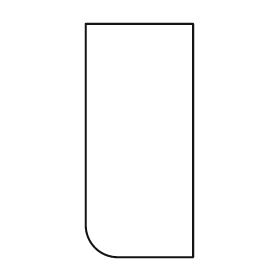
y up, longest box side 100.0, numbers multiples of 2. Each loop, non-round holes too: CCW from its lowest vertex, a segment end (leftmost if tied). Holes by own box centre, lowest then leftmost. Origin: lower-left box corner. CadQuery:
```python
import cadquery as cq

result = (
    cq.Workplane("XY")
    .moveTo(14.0, 0.0)
    .lineTo(46.0, 0.0)
    .lineTo(46.0, 100.0)
    .lineTo(0.0, 100.0)
    .lineTo(0.0, 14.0)
    .threePointArc((4.0, 4.0), (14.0, 0.0))
    .close()
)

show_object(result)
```